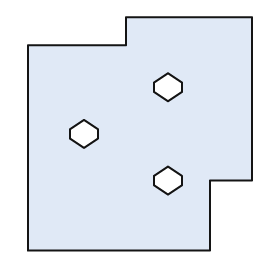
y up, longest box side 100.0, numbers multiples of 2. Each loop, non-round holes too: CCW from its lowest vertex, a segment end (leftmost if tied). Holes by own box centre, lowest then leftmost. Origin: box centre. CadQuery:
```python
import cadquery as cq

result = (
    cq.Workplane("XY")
    .moveTo(-48.0, -50.0)
    .lineTo(30.0, -50.0)
    .lineTo(30.0, -20.0)
    .lineTo(48.0, -20.0)
    .lineTo(48.0, 50.0)
    .lineTo(-6.0, 50.0)
    .lineTo(-6.0, 38.0)
    .lineTo(-48.0, 38.0)
    .close()
    .moveTo(12.0, -26.0)
    .lineTo(18.0, -22.0)
    .lineTo(18.0, -18.0)
    .lineTo(12.0, -14.0)
    .lineTo(6.0, -18.0)
    .lineTo(6.0, -22.0)
    .close()
    .moveTo(-24.0, -6.0)
    .lineTo(-18.0, -2.0)
    .lineTo(-18.0, 2.0)
    .lineTo(-24.0, 6.0)
    .lineTo(-30.0, 2.0)
    .lineTo(-30.0, -2.0)
    .close()
    .moveTo(12.0, 14.0)
    .lineTo(18.0, 18.0)
    .lineTo(18.0, 22.0)
    .lineTo(12.0, 26.0)
    .lineTo(6.0, 22.0)
    .lineTo(6.0, 18.0)
    .close()
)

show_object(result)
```